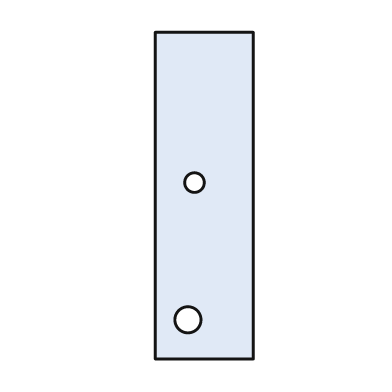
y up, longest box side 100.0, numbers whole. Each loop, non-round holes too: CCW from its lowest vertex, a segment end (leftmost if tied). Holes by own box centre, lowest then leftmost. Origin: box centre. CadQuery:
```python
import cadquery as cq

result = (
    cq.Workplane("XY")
    .moveTo(-15.0, -50.0)
    .lineTo(15.0, -50.0)
    .lineTo(15.0, 50.0)
    .lineTo(-15.0, 50.0)
    .close()
    .moveTo(-5.0, -38.0)
    .circle(4.0)
    .moveTo(-3.0, 4.0)
    .circle(3.0)
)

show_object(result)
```